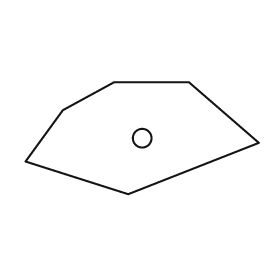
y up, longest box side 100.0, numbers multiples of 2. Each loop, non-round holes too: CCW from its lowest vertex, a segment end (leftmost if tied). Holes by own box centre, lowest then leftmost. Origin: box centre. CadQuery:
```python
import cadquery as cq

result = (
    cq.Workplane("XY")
    .moveTo(-6.0, -24.0)
    .lineTo(50.0, -2.0)
    .lineTo(20.0, 24.0)
    .lineTo(-12.0, 24.0)
    .lineTo(-34.0, 12.0)
    .lineTo(-50.0, -10.0)
    .close()
    .moveTo(0.0, 0.0)
    .circle(4.0)
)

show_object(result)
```